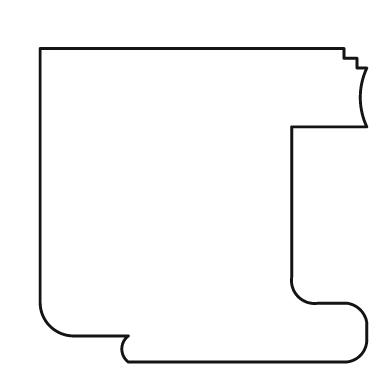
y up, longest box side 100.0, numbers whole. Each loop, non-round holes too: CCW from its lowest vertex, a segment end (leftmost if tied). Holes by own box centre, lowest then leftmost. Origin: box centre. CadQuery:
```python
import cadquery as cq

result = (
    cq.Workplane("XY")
    .moveTo(-23.0, -48.0)
    .lineTo(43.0, -48.0)
    .threePointArc((48.0, -46.0), (50.0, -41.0))
    .lineTo(50.0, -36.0)
    .threePointArc((48.0, -32.0), (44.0, -30.0))
    .lineTo(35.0, -30.0)
    .threePointArc((29.0, -28.0), (27.0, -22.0))
    .lineTo(27.0, 24.0)
    .lineTo(50.0, 24.0)
    .threePointArc((48.0, 33.0), (50.0, 42.0))
    .lineTo(47.0, 42.0)
    .lineTo(47.0, 45.0)
    .lineTo(43.0, 45.0)
    .lineTo(43.0, 48.0)
    .lineTo(-50.0, 48.0)
    .lineTo(-50.0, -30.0)
    .threePointArc((-47.0, -37.0), (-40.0, -40.0))
    .lineTo(-23.0, -40.0)
    .threePointArc((-25.0, -44.0), (-23.0, -48.0))
    .close()
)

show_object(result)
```